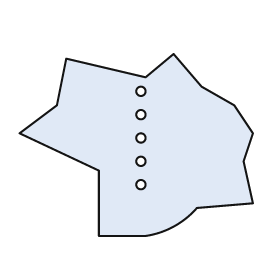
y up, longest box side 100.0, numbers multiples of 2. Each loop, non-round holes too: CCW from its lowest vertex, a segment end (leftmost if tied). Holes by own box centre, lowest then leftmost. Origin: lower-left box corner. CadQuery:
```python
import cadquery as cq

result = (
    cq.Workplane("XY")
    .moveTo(34.0, 0.0)
    .lineTo(54.0, 0.0)
    .threePointArc((66.0, 4.0), (76.0, 12.0))
    .lineTo(100.0, 14.0)
    .lineTo(96.0, 32.0)
    .lineTo(100.0, 44.0)
    .lineTo(92.0, 56.0)
    .lineTo(78.0, 64.0)
    .lineTo(66.0, 78.0)
    .lineTo(54.0, 68.0)
    .lineTo(20.0, 76.0)
    .lineTo(16.0, 56.0)
    .lineTo(0.0, 44.0)
    .lineTo(34.0, 28.0)
    .close()
    .moveTo(52.0, 22.0)
    .circle(2.0)
    .moveTo(52.0, 32.0)
    .circle(2.0)
    .moveTo(52.0, 42.0)
    .circle(2.0)
    .moveTo(52.0, 52.0)
    .circle(2.0)
    .moveTo(52.0, 62.0)
    .circle(2.0)
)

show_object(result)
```